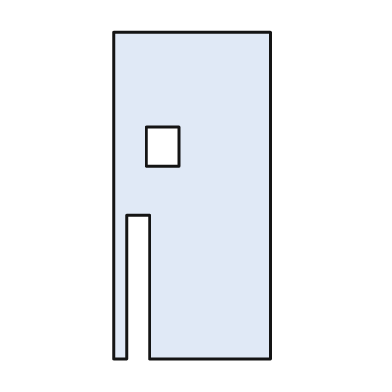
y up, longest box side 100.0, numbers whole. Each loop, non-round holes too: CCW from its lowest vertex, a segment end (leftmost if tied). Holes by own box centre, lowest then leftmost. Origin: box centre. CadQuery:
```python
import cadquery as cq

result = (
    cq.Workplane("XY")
    .moveTo(-24.0, -50.0)
    .lineTo(-20.0, -50.0)
    .lineTo(-20.0, -6.0)
    .lineTo(-13.0, -6.0)
    .lineTo(-13.0, -50.0)
    .lineTo(24.0, -50.0)
    .lineTo(24.0, 50.0)
    .lineTo(-24.0, 50.0)
    .close()
    .moveTo(-14.0, 9.0)
    .lineTo(-4.0, 9.0)
    .lineTo(-4.0, 21.0)
    .lineTo(-14.0, 21.0)
    .close()
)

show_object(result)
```